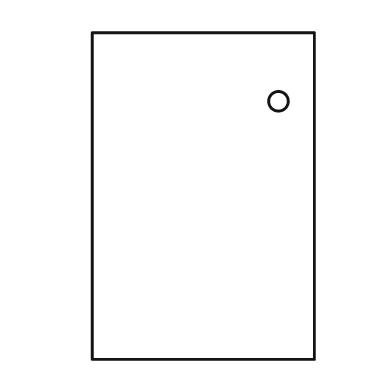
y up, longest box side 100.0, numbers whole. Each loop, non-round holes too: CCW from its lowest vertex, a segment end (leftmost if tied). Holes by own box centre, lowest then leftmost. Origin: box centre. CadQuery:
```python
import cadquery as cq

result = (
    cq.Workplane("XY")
    .moveTo(-34.0, -50.0)
    .lineTo(34.0, -50.0)
    .lineTo(34.0, 50.0)
    .lineTo(-34.0, 50.0)
    .close()
    .moveTo(23.0, 29.0)
    .circle(3.0)
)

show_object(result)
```